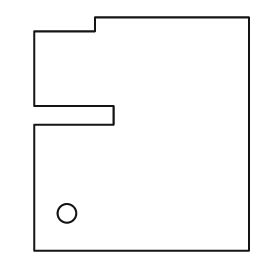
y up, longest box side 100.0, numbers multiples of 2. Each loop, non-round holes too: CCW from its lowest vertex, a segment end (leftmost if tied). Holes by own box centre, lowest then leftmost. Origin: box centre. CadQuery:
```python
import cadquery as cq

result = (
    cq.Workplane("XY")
    .moveTo(-46.0, -50.0)
    .lineTo(46.0, -50.0)
    .lineTo(46.0, 50.0)
    .lineTo(-20.0, 50.0)
    .lineTo(-20.0, 44.0)
    .lineTo(-46.0, 44.0)
    .lineTo(-46.0, 12.0)
    .lineTo(-12.0, 12.0)
    .lineTo(-12.0, 4.0)
    .lineTo(-46.0, 4.0)
    .close()
    .moveTo(-32.0, -34.0)
    .circle(4.0)
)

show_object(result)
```